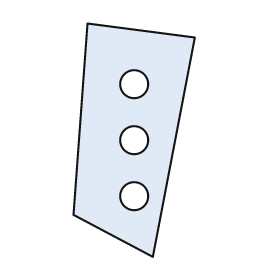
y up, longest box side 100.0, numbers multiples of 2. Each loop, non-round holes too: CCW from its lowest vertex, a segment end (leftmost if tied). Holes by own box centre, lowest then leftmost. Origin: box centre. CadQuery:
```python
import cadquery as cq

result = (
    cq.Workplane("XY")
    .moveTo(8.0, -50.0)
    .lineTo(26.0, 44.0)
    .lineTo(-20.0, 50.0)
    .lineTo(-26.0, -32.0)
    .close()
    .moveTo(0.0, -24.0)
    .circle(6.0)
    .moveTo(0.0, 0.0)
    .circle(6.0)
    .moveTo(0.0, 24.0)
    .circle(6.0)
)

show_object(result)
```